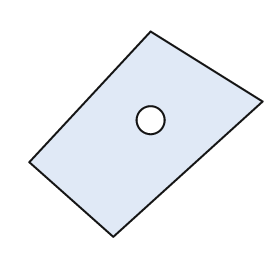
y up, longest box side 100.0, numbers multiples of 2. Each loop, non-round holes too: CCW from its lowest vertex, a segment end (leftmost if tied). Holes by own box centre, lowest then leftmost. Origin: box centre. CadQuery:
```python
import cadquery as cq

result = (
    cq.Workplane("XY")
    .moveTo(-14.0, -44.0)
    .lineTo(50.0, 14.0)
    .lineTo(2.0, 44.0)
    .lineTo(-50.0, -12.0)
    .close()
    .moveTo(2.0, 6.0)
    .circle(6.0)
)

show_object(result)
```